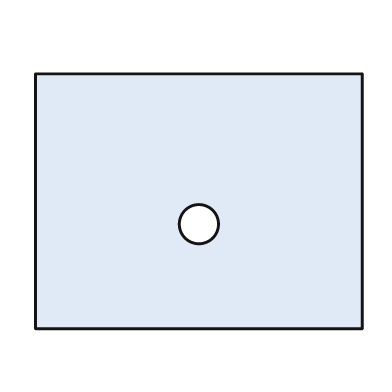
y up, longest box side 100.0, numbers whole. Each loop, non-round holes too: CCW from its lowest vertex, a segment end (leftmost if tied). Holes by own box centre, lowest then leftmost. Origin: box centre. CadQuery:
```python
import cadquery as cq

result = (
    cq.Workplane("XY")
    .moveTo(-50.0, -39.0)
    .lineTo(50.0, -39.0)
    .lineTo(50.0, 39.0)
    .lineTo(-50.0, 39.0)
    .close()
    .moveTo(0.0, -7.0)
    .circle(6.0)
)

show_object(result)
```